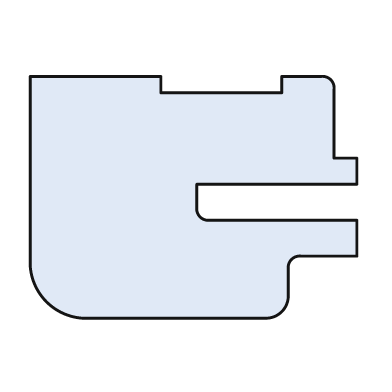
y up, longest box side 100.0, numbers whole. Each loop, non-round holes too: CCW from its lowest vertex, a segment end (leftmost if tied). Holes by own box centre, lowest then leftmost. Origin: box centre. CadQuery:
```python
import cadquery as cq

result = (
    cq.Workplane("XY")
    .moveTo(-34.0, -37.0)
    .lineTo(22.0, -37.0)
    .threePointArc((27.0, -35.0), (29.0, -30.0))
    .lineTo(29.0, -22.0)
    .threePointArc((30.0, -19.0), (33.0, -18.0))
    .lineTo(50.0, -18.0)
    .lineTo(50.0, -7.0)
    .lineTo(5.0, -7.0)
    .threePointArc((2.0, -6.0), (1.0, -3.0))
    .lineTo(1.0, 4.0)
    .lineTo(50.0, 4.0)
    .lineTo(50.0, 12.0)
    .lineTo(43.0, 12.0)
    .lineTo(43.0, 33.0)
    .threePointArc((42.0, 36.0), (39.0, 37.0))
    .lineTo(27.0, 37.0)
    .lineTo(27.0, 32.0)
    .lineTo(-10.0, 32.0)
    .lineTo(-10.0, 37.0)
    .lineTo(-50.0, 37.0)
    .lineTo(-50.0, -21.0)
    .threePointArc((-45.0, -32.0), (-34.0, -37.0))
    .close()
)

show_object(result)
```